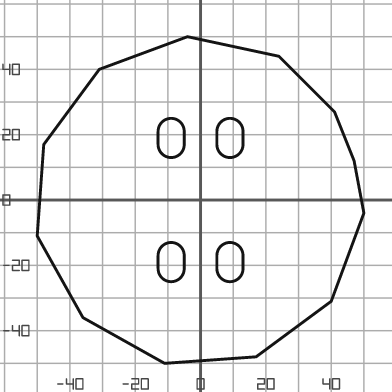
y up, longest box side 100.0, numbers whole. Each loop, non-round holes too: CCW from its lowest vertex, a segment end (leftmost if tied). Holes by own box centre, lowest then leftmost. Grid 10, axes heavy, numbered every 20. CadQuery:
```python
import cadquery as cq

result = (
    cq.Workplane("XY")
    .moveTo(-11.0, -50.0)
    .lineTo(17.0, -48.0)
    .lineTo(40.0, -31.0)
    .lineTo(50.0, -4.0)
    .lineTo(47.0, 12.0)
    .lineTo(41.0, 27.0)
    .lineTo(24.0, 44.0)
    .lineTo(-4.0, 50.0)
    .lineTo(-31.0, 40.0)
    .lineTo(-48.0, 17.0)
    .lineTo(-50.0, -11.0)
    .lineTo(-36.0, -36.0)
    .close()
    .moveTo(-13.0, -21.0)
    .threePointArc((-9.0, -25.0), (-5.0, -21.0))
    .lineTo(-5.0, -17.0)
    .threePointArc((-9.0, -13.0), (-13.0, -17.0))
    .close()
    .moveTo(5.0, -21.0)
    .threePointArc((9.0, -25.0), (13.0, -21.0))
    .lineTo(13.0, -17.0)
    .threePointArc((9.0, -13.0), (5.0, -17.0))
    .close()
    .moveTo(-13.0, 17.0)
    .threePointArc((-9.0, 13.0), (-5.0, 17.0))
    .lineTo(-5.0, 21.0)
    .threePointArc((-9.0, 25.0), (-13.0, 21.0))
    .close()
    .moveTo(5.0, 17.0)
    .threePointArc((9.0, 13.0), (13.0, 17.0))
    .lineTo(13.0, 21.0)
    .threePointArc((9.0, 25.0), (5.0, 21.0))
    .close()
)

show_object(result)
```